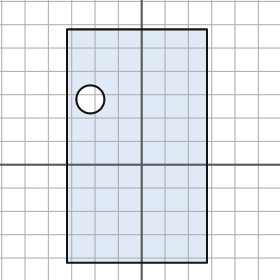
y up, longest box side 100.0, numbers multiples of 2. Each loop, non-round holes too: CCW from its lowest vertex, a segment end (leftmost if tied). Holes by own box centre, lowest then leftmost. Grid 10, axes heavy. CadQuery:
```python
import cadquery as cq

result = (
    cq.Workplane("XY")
    .moveTo(-32.0, -42.0)
    .lineTo(28.0, -42.0)
    .lineTo(28.0, 58.0)
    .lineTo(-32.0, 58.0)
    .close()
    .moveTo(-22.0, 28.0)
    .circle(6.0)
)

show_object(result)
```